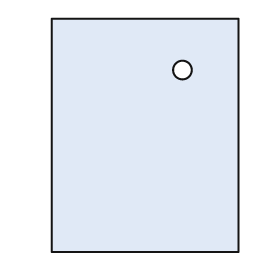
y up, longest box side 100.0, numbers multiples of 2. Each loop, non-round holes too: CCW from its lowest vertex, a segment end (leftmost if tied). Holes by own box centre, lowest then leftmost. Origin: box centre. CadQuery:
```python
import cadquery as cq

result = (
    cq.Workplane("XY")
    .moveTo(-40.0, -50.0)
    .lineTo(40.0, -50.0)
    .lineTo(40.0, 50.0)
    .lineTo(-40.0, 50.0)
    .close()
    .moveTo(16.0, 28.0)
    .circle(4.0)
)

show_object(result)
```